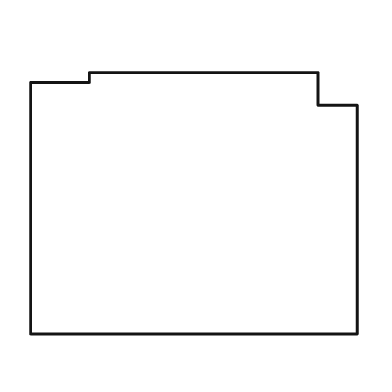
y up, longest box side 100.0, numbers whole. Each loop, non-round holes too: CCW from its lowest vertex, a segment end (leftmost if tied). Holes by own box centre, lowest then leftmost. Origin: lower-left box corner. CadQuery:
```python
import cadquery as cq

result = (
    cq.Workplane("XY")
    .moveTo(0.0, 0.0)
    .lineTo(100.0, 0.0)
    .lineTo(100.0, 70.0)
    .lineTo(88.0, 70.0)
    .lineTo(88.0, 80.0)
    .lineTo(18.0, 80.0)
    .lineTo(18.0, 77.0)
    .lineTo(0.0, 77.0)
    .close()
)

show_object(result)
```